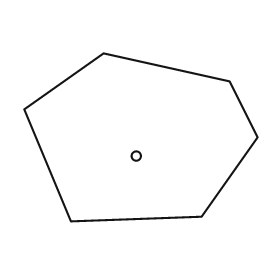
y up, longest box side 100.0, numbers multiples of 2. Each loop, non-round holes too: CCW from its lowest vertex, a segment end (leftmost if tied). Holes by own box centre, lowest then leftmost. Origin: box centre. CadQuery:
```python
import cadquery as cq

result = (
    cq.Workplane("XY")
    .moveTo(-30.0, -36.0)
    .lineTo(26.0, -34.0)
    .lineTo(50.0, 0.0)
    .lineTo(38.0, 24.0)
    .lineTo(-16.0, 36.0)
    .lineTo(-50.0, 12.0)
    .close()
    .moveTo(-2.0, -8.0)
    .circle(2.0)
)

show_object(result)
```